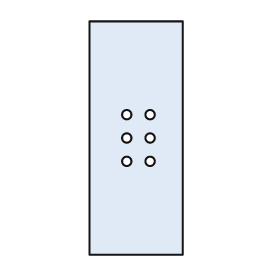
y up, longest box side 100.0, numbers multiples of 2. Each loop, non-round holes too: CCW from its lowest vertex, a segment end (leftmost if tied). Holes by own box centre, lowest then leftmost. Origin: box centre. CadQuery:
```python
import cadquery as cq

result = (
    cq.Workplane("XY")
    .moveTo(-20.0, -50.0)
    .lineTo(20.0, -50.0)
    .lineTo(20.0, 50.0)
    .lineTo(-20.0, 50.0)
    .close()
    .moveTo(-4.0, -10.0)
    .circle(2.0)
    .moveTo(6.0, -10.0)
    .circle(2.0)
    .moveTo(-4.0, 0.0)
    .circle(2.0)
    .moveTo(6.0, 0.0)
    .circle(2.0)
    .moveTo(-4.0, 10.0)
    .circle(2.0)
    .moveTo(6.0, 10.0)
    .circle(2.0)
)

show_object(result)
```